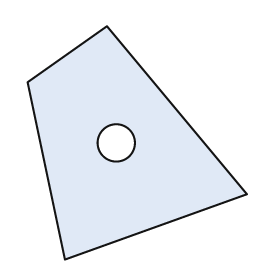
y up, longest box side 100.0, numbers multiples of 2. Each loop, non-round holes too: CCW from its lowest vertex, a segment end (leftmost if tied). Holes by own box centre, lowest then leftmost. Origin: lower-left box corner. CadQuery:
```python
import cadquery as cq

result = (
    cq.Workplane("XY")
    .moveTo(16.0, 0.0)
    .lineTo(94.0, 28.0)
    .lineTo(34.0, 100.0)
    .lineTo(0.0, 76.0)
    .close()
    .moveTo(38.0, 50.0)
    .circle(8.0)
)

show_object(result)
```